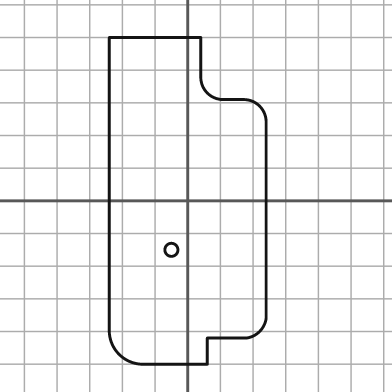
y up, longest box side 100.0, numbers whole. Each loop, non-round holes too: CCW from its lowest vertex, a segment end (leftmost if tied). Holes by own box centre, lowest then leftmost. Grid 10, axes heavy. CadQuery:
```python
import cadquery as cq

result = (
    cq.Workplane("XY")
    .moveTo(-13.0, -50.0)
    .lineTo(6.0, -50.0)
    .lineTo(6.0, -42.0)
    .lineTo(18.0, -42.0)
    .threePointArc((22.0, -40.0), (24.0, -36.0))
    .lineTo(24.0, 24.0)
    .threePointArc((22.0, 29.0), (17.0, 31.0))
    .lineTo(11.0, 31.0)
    .threePointArc((6.0, 33.0), (4.0, 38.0))
    .lineTo(4.0, 50.0)
    .lineTo(-24.0, 50.0)
    .lineTo(-24.0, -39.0)
    .threePointArc((-21.0, -47.0), (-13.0, -50.0))
    .close()
    .moveTo(-5.0, -15.0)
    .circle(2.0)
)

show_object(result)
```